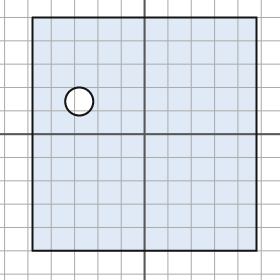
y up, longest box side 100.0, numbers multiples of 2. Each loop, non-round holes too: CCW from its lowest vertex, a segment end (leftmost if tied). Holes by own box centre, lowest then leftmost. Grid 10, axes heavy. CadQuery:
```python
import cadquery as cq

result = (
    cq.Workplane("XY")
    .moveTo(-48.0, -50.0)
    .lineTo(48.0, -50.0)
    .lineTo(48.0, 50.0)
    .lineTo(-48.0, 50.0)
    .close()
    .moveTo(-28.0, 14.0)
    .circle(6.0)
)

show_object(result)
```